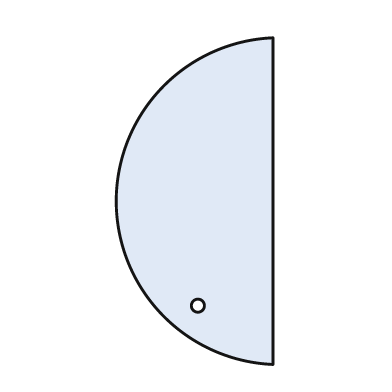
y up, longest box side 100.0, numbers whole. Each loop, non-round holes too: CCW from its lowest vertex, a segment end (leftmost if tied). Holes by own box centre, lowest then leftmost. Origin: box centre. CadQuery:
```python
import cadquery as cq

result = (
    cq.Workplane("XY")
    .moveTo(24.0, -50.0)
    .lineTo(24.0, 50.0)
    .threePointArc((-24.0, 0.0), (24.0, -50.0))
    .close()
    .moveTo(1.0, -32.0)
    .circle(2.0)
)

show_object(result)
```